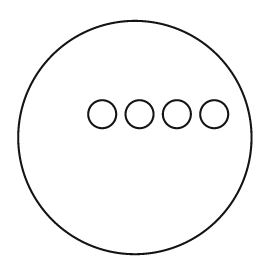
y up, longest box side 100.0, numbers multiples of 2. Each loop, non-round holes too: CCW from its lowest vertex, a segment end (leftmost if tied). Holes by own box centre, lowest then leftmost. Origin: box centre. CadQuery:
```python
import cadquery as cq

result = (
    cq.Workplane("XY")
    .moveTo(0.0, 0.0)
    .circle(50.0)
    .moveTo(-14.0, 10.0)
    .circle(6.0)
    .moveTo(2.0, 10.0)
    .circle(6.0)
    .moveTo(18.0, 10.0)
    .circle(6.0)
    .moveTo(34.0, 10.0)
    .circle(6.0)
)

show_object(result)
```